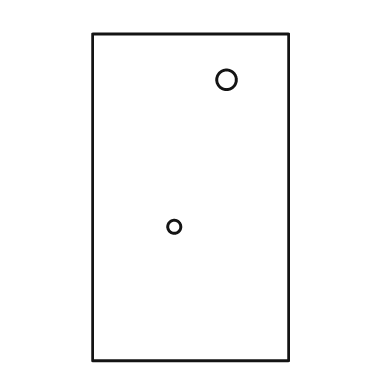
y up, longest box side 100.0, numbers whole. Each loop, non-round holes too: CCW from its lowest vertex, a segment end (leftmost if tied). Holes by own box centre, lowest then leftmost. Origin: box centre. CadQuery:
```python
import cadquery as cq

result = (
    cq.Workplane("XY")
    .moveTo(-30.0, -50.0)
    .lineTo(30.0, -50.0)
    .lineTo(30.0, 50.0)
    .lineTo(-30.0, 50.0)
    .close()
    .moveTo(-5.0, -9.0)
    .circle(2.0)
    .moveTo(11.0, 36.0)
    .circle(3.0)
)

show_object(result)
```